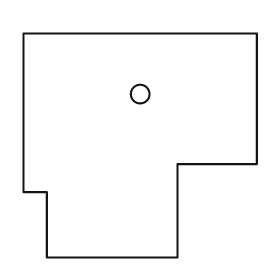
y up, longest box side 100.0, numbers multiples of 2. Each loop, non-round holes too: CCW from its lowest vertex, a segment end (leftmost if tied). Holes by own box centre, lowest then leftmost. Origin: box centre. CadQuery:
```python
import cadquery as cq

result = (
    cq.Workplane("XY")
    .moveTo(-40.0, -48.0)
    .lineTo(16.0, -48.0)
    .lineTo(16.0, -8.0)
    .lineTo(50.0, -8.0)
    .lineTo(50.0, 48.0)
    .lineTo(-50.0, 48.0)
    .lineTo(-50.0, -20.0)
    .lineTo(-40.0, -20.0)
    .close()
    .moveTo(0.0, 22.0)
    .circle(4.0)
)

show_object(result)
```